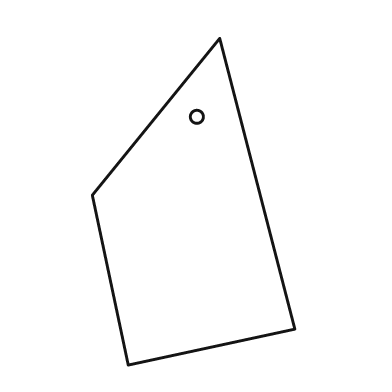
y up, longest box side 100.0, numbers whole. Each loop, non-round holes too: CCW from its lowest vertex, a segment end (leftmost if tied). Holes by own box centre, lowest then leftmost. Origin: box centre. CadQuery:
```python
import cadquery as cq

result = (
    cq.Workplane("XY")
    .moveTo(-20.0, -50.0)
    .lineTo(31.0, -39.0)
    .lineTo(8.0, 50.0)
    .lineTo(-31.0, 2.0)
    .close()
    .moveTo(1.0, 26.0)
    .circle(2.0)
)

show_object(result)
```